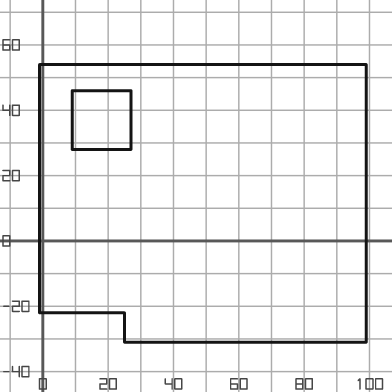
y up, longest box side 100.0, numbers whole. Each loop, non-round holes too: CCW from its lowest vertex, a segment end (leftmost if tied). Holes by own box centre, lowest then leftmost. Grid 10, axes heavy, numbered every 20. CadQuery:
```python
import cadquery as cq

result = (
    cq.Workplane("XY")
    .moveTo(25.0, -31.0)
    .lineTo(99.0, -31.0)
    .lineTo(99.0, 54.0)
    .lineTo(-1.0, 54.0)
    .lineTo(-1.0, -22.0)
    .lineTo(25.0, -22.0)
    .close()
    .moveTo(9.0, 28.0)
    .lineTo(27.0, 28.0)
    .lineTo(27.0, 46.0)
    .lineTo(9.0, 46.0)
    .close()
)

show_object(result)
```